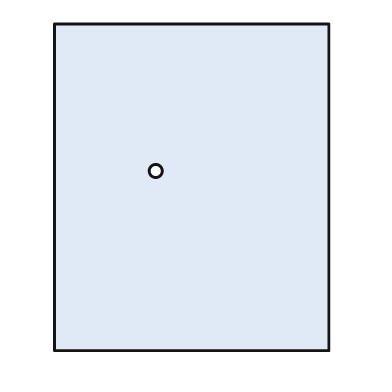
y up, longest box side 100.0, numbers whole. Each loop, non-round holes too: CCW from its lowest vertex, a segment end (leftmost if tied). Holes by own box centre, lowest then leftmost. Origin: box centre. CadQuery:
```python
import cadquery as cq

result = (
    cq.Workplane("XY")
    .moveTo(-42.0, -50.0)
    .lineTo(42.0, -50.0)
    .lineTo(42.0, 50.0)
    .lineTo(-42.0, 50.0)
    .close()
    .moveTo(-11.0, 5.0)
    .circle(2.0)
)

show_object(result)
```